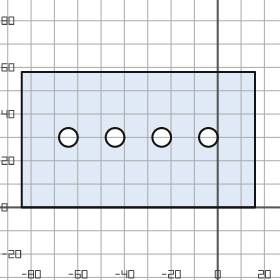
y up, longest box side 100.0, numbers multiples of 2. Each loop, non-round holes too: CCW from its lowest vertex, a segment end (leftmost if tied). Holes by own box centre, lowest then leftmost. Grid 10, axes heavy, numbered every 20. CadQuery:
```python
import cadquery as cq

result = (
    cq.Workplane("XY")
    .moveTo(-84.0, 0.0)
    .lineTo(16.0, 0.0)
    .lineTo(16.0, 58.0)
    .lineTo(-84.0, 58.0)
    .close()
    .moveTo(-64.0, 30.0)
    .circle(4.0)
    .moveTo(-44.0, 30.0)
    .circle(4.0)
    .moveTo(-24.0, 30.0)
    .circle(4.0)
    .moveTo(-4.0, 30.0)
    .circle(4.0)
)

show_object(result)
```